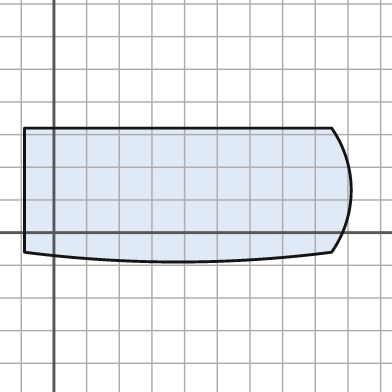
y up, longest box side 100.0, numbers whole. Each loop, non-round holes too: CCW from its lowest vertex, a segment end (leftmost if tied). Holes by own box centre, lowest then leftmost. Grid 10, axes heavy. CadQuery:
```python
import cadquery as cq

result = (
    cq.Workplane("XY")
    .moveTo(-9.0, -6.0)
    .threePointArc((38.0, -9.0), (85.0, -6.0))
    .threePointArc((91.0, 13.0), (85.0, 32.0))
    .lineTo(-9.0, 32.0)
    .close()
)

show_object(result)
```